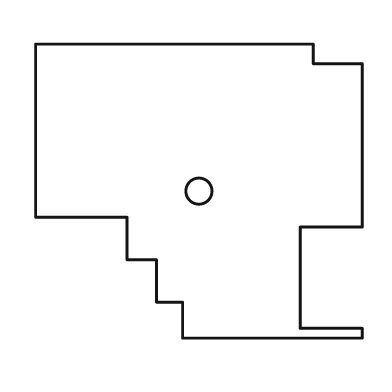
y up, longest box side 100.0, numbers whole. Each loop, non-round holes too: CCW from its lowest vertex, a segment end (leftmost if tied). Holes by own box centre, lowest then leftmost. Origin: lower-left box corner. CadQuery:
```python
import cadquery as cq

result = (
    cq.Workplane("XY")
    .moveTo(45.0, 0.0)
    .lineTo(100.0, 0.0)
    .lineTo(100.0, 3.0)
    .lineTo(81.0, 3.0)
    .lineTo(81.0, 34.0)
    .lineTo(100.0, 34.0)
    .lineTo(100.0, 84.0)
    .lineTo(85.0, 84.0)
    .lineTo(85.0, 90.0)
    .lineTo(0.0, 90.0)
    .lineTo(0.0, 37.0)
    .lineTo(28.0, 37.0)
    .lineTo(28.0, 24.0)
    .lineTo(37.0, 24.0)
    .lineTo(37.0, 11.0)
    .lineTo(45.0, 11.0)
    .close()
    .moveTo(50.0, 45.0)
    .circle(4.0)
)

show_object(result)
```